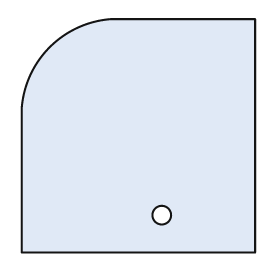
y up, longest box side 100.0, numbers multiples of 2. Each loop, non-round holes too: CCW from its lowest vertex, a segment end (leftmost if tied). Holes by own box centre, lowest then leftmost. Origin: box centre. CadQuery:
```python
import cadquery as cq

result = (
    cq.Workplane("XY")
    .moveTo(-50.0, -50.0)
    .lineTo(50.0, -50.0)
    .lineTo(50.0, 50.0)
    .lineTo(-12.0, 50.0)
    .threePointArc((-38.0, 38.0), (-50.0, 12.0))
    .close()
    .moveTo(10.0, -34.0)
    .circle(4.0)
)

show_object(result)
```